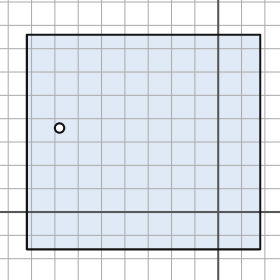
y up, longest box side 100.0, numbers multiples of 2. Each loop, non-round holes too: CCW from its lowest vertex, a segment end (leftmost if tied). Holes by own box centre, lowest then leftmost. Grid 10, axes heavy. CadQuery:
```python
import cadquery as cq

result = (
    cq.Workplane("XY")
    .moveTo(-82.0, -16.0)
    .lineTo(18.0, -16.0)
    .lineTo(18.0, 76.0)
    .lineTo(-82.0, 76.0)
    .close()
    .moveTo(-68.0, 36.0)
    .circle(2.0)
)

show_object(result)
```